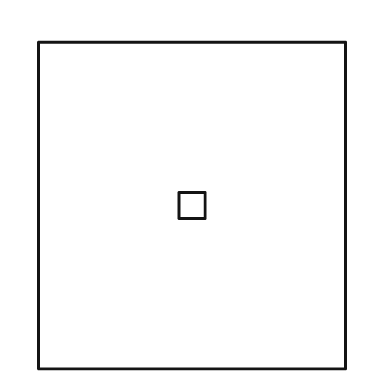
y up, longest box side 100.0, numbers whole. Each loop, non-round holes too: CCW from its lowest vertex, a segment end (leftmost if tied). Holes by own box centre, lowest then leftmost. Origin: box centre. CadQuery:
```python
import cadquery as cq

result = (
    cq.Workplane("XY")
    .moveTo(-47.0, -50.0)
    .lineTo(47.0, -50.0)
    .lineTo(47.0, 50.0)
    .lineTo(-47.0, 50.0)
    .close()
    .moveTo(-4.0, -4.0)
    .lineTo(4.0, -4.0)
    .lineTo(4.0, 4.0)
    .lineTo(-4.0, 4.0)
    .close()
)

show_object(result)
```